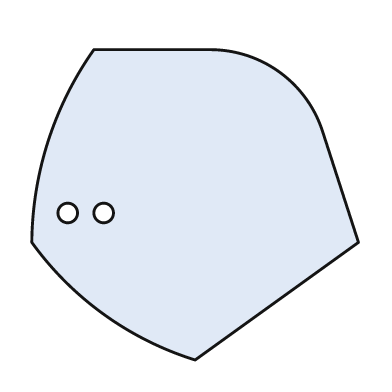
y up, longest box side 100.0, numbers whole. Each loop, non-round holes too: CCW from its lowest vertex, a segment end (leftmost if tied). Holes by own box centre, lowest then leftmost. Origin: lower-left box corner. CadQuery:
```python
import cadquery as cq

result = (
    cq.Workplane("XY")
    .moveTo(50.0, 0.0)
    .lineTo(100.0, 36.0)
    .lineTo(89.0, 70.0)
    .threePointArc((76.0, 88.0), (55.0, 95.0))
    .lineTo(19.0, 95.0)
    .threePointArc((5.0, 67.0), (0.0, 36.0))
    .threePointArc((22.0, 14.0), (50.0, 0.0))
    .close()
    .moveTo(11.0, 45.0)
    .circle(3.0)
    .moveTo(22.0, 45.0)
    .circle(3.0)
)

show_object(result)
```